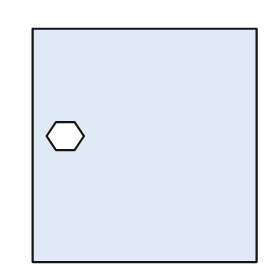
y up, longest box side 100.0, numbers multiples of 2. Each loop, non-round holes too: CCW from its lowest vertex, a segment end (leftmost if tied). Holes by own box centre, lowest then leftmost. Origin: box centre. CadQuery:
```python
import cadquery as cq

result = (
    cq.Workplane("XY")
    .moveTo(-48.0, -50.0)
    .lineTo(48.0, -50.0)
    .lineTo(48.0, 50.0)
    .lineTo(-48.0, 50.0)
    .close()
    .moveTo(-38.0, -2.0)
    .lineTo(-30.0, -2.0)
    .lineTo(-26.0, 4.0)
    .lineTo(-30.0, 10.0)
    .lineTo(-38.0, 10.0)
    .lineTo(-42.0, 4.0)
    .close()
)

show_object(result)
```